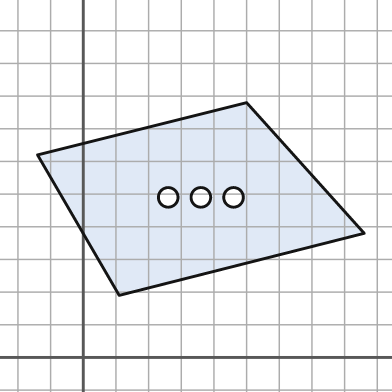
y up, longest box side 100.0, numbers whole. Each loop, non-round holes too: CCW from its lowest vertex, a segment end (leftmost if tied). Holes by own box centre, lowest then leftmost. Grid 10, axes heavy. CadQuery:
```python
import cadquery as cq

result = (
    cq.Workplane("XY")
    .moveTo(11.0, 19.0)
    .lineTo(86.0, 38.0)
    .lineTo(50.0, 78.0)
    .lineTo(-14.0, 62.0)
    .close()
    .moveTo(26.0, 49.0)
    .circle(3.0)
    .moveTo(36.0, 49.0)
    .circle(3.0)
    .moveTo(46.0, 49.0)
    .circle(3.0)
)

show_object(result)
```